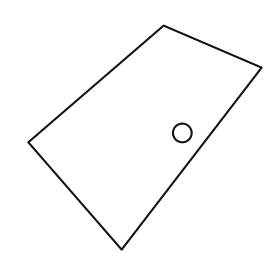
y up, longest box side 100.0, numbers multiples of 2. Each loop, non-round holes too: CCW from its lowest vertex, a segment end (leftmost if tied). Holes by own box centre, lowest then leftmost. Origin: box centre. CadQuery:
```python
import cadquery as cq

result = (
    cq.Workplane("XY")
    .moveTo(-10.0, -48.0)
    .lineTo(50.0, 30.0)
    .lineTo(8.0, 48.0)
    .lineTo(-50.0, -2.0)
    .close()
    .moveTo(16.0, 2.0)
    .circle(4.0)
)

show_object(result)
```